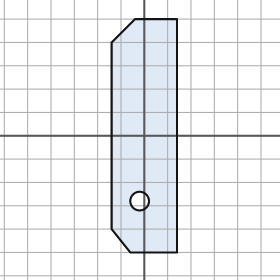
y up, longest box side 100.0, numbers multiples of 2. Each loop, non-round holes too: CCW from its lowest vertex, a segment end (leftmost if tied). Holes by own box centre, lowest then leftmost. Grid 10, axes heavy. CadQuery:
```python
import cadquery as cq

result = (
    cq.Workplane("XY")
    .moveTo(-6.0, -50.0)
    .lineTo(14.0, -50.0)
    .lineTo(14.0, 50.0)
    .lineTo(-4.0, 50.0)
    .lineTo(-14.0, 40.0)
    .lineTo(-14.0, -40.0)
    .close()
    .moveTo(-2.0, -28.0)
    .circle(4.0)
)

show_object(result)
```